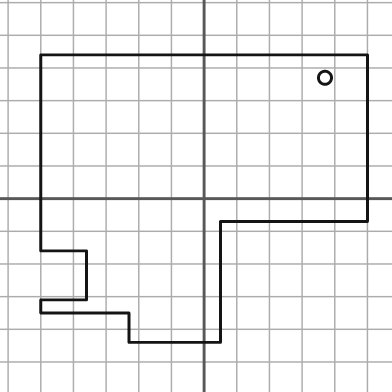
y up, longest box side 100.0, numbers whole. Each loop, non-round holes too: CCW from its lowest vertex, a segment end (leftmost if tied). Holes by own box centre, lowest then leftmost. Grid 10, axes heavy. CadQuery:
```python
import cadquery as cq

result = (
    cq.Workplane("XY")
    .moveTo(-23.0, -44.0)
    .lineTo(5.0, -44.0)
    .lineTo(5.0, -7.0)
    .lineTo(50.0, -7.0)
    .lineTo(50.0, 44.0)
    .lineTo(-50.0, 44.0)
    .lineTo(-50.0, -16.0)
    .lineTo(-36.0, -16.0)
    .lineTo(-36.0, -31.0)
    .lineTo(-50.0, -31.0)
    .lineTo(-50.0, -35.0)
    .lineTo(-23.0, -35.0)
    .close()
    .moveTo(37.0, 37.0)
    .circle(2.0)
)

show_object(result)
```